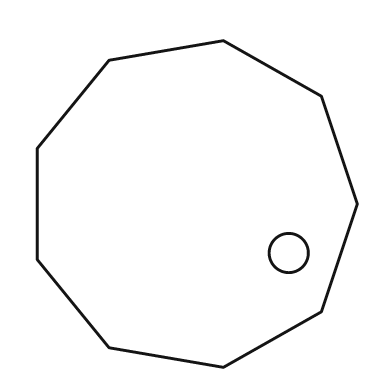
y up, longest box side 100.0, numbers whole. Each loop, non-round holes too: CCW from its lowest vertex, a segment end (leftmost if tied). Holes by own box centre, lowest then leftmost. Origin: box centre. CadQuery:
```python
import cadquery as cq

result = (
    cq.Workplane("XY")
    .moveTo(8.0, -50.0)
    .lineTo(38.0, -33.0)
    .lineTo(49.0, 0.0)
    .lineTo(38.0, 33.0)
    .lineTo(8.0, 50.0)
    .lineTo(-27.0, 44.0)
    .lineTo(-49.0, 17.0)
    .lineTo(-49.0, -17.0)
    .lineTo(-27.0, -44.0)
    .close()
    .moveTo(28.0, -15.0)
    .circle(6.0)
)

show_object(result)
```